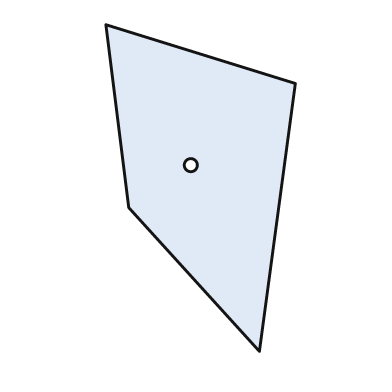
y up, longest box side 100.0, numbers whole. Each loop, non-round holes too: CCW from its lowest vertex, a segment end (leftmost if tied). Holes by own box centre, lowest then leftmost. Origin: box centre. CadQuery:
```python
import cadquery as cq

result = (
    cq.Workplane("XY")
    .moveTo(18.0, -50.0)
    .lineTo(29.0, 32.0)
    .lineTo(-29.0, 50.0)
    .lineTo(-22.0, -6.0)
    .close()
    .moveTo(-3.0, 7.0)
    .circle(2.0)
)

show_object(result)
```